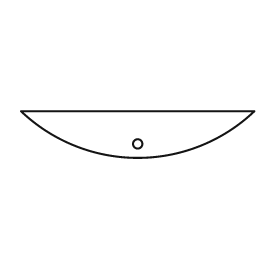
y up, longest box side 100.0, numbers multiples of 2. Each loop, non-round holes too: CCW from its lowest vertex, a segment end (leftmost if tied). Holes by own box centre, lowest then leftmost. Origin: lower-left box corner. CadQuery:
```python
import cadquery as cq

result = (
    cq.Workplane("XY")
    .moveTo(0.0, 20.0)
    .threePointArc((50.0, 0.0), (100.0, 20.0))
    .close()
    .moveTo(50.0, 6.0)
    .circle(2.0)
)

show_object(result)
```